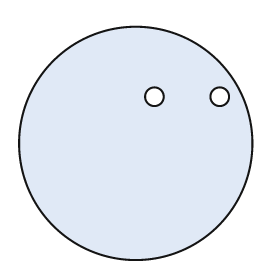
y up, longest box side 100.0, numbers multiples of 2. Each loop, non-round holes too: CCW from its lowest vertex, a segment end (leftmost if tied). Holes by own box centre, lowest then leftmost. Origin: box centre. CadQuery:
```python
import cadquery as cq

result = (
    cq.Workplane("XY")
    .moveTo(0.0, 0.0)
    .circle(50.0)
    .moveTo(8.0, 20.0)
    .circle(4.0)
    .moveTo(36.0, 20.0)
    .circle(4.0)
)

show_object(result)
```